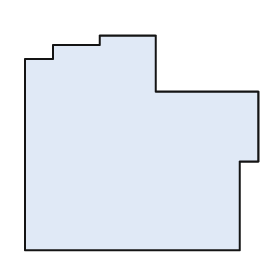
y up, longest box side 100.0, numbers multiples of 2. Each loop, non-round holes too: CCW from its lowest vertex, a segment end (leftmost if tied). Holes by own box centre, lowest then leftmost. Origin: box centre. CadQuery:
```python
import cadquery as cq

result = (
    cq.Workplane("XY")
    .moveTo(-50.0, -46.0)
    .lineTo(42.0, -46.0)
    .lineTo(42.0, -8.0)
    .lineTo(50.0, -8.0)
    .lineTo(50.0, 22.0)
    .lineTo(6.0, 22.0)
    .lineTo(6.0, 46.0)
    .lineTo(-18.0, 46.0)
    .lineTo(-18.0, 42.0)
    .lineTo(-38.0, 42.0)
    .lineTo(-38.0, 36.0)
    .lineTo(-50.0, 36.0)
    .close()
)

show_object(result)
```